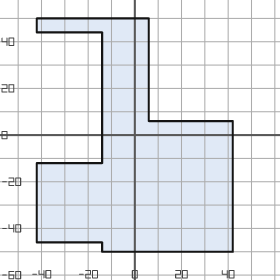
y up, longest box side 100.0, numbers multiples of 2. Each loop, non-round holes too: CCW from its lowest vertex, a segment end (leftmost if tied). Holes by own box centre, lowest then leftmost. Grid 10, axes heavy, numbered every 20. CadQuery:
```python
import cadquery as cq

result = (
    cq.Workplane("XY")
    .moveTo(-14.0, -50.0)
    .lineTo(42.0, -50.0)
    .lineTo(42.0, 6.0)
    .lineTo(6.0, 6.0)
    .lineTo(6.0, 50.0)
    .lineTo(-42.0, 50.0)
    .lineTo(-42.0, 44.0)
    .lineTo(-14.0, 44.0)
    .lineTo(-14.0, -12.0)
    .lineTo(-42.0, -12.0)
    .lineTo(-42.0, -46.0)
    .lineTo(-14.0, -46.0)
    .close()
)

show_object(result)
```